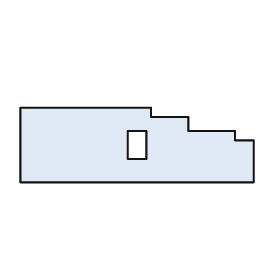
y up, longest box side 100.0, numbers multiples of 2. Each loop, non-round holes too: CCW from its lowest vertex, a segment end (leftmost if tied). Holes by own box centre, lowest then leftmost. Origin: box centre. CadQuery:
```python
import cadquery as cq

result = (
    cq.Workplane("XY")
    .moveTo(-50.0, -16.0)
    .lineTo(50.0, -16.0)
    .lineTo(50.0, 2.0)
    .lineTo(42.0, 2.0)
    .lineTo(42.0, 6.0)
    .lineTo(22.0, 6.0)
    .lineTo(22.0, 12.0)
    .lineTo(6.0, 12.0)
    .lineTo(6.0, 16.0)
    .lineTo(-50.0, 16.0)
    .close()
    .moveTo(-4.0, -6.0)
    .lineTo(4.0, -6.0)
    .lineTo(4.0, 6.0)
    .lineTo(-4.0, 6.0)
    .close()
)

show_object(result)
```